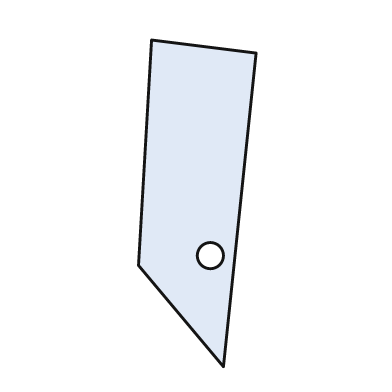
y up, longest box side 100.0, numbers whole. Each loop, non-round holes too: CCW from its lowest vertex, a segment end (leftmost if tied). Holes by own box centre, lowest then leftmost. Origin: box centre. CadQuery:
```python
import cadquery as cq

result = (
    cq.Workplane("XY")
    .moveTo(8.0, -50.0)
    .lineTo(18.0, 46.0)
    .lineTo(-14.0, 50.0)
    .lineTo(-18.0, -19.0)
    .close()
    .moveTo(4.0, -16.0)
    .circle(4.0)
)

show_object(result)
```